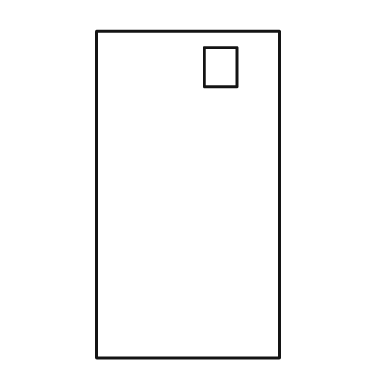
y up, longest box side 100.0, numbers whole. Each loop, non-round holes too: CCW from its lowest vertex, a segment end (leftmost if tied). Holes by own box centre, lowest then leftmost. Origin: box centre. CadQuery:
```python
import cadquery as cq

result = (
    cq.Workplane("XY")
    .moveTo(-28.0, -50.0)
    .lineTo(28.0, -50.0)
    .lineTo(28.0, 50.0)
    .lineTo(-28.0, 50.0)
    .close()
    .moveTo(5.0, 33.0)
    .lineTo(15.0, 33.0)
    .lineTo(15.0, 45.0)
    .lineTo(5.0, 45.0)
    .close()
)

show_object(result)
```